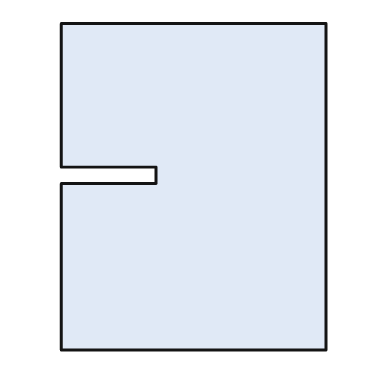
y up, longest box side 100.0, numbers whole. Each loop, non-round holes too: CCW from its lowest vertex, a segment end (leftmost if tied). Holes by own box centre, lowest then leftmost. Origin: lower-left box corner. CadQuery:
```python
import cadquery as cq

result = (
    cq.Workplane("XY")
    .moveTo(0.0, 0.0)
    .lineTo(81.0, 0.0)
    .lineTo(81.0, 100.0)
    .lineTo(0.0, 100.0)
    .lineTo(0.0, 56.0)
    .lineTo(29.0, 56.0)
    .lineTo(29.0, 51.0)
    .lineTo(0.0, 51.0)
    .close()
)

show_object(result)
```